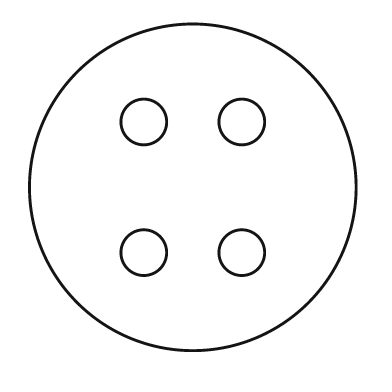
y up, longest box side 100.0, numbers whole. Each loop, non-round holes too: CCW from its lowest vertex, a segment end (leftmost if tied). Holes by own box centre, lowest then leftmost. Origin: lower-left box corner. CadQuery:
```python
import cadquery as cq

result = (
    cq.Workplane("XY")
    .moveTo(50.0, 50.0)
    .circle(50.0)
    .moveTo(35.0, 30.0)
    .circle(7.0)
    .moveTo(65.0, 30.0)
    .circle(7.0)
    .moveTo(35.0, 70.0)
    .circle(7.0)
    .moveTo(65.0, 70.0)
    .circle(7.0)
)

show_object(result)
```